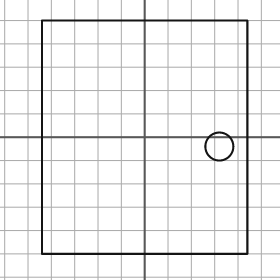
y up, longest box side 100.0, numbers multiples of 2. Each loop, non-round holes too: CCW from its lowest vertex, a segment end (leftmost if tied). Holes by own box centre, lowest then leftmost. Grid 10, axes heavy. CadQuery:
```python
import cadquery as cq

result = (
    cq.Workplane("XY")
    .moveTo(-44.0, -50.0)
    .lineTo(44.0, -50.0)
    .lineTo(44.0, 50.0)
    .lineTo(-44.0, 50.0)
    .close()
    .moveTo(32.0, -4.0)
    .circle(6.0)
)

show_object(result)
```